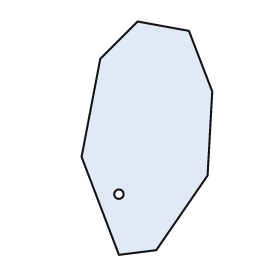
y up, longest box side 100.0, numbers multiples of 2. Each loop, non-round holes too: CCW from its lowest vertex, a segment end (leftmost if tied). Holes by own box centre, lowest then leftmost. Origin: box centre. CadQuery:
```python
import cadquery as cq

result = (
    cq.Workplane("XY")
    .moveTo(-12.0, -50.0)
    .lineTo(4.0, -48.0)
    .lineTo(26.0, -16.0)
    .lineTo(28.0, 20.0)
    .lineTo(18.0, 46.0)
    .lineTo(-4.0, 50.0)
    .lineTo(-20.0, 34.0)
    .lineTo(-28.0, -8.0)
    .close()
    .moveTo(-12.0, -24.0)
    .circle(2.0)
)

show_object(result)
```